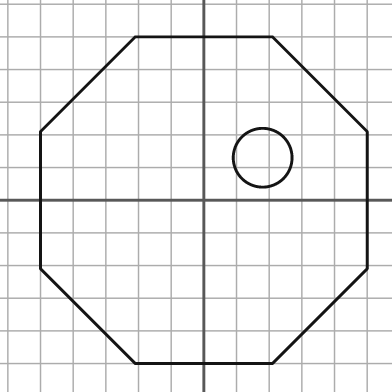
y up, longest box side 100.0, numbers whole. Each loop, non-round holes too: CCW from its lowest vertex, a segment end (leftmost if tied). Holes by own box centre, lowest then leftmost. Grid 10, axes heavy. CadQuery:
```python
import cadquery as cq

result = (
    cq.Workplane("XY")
    .moveTo(-21.0, -50.0)
    .lineTo(21.0, -50.0)
    .lineTo(50.0, -21.0)
    .lineTo(50.0, 21.0)
    .lineTo(21.0, 50.0)
    .lineTo(-21.0, 50.0)
    .lineTo(-50.0, 21.0)
    .lineTo(-50.0, -21.0)
    .close()
    .moveTo(18.0, 13.0)
    .circle(9.0)
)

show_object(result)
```